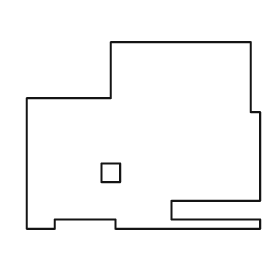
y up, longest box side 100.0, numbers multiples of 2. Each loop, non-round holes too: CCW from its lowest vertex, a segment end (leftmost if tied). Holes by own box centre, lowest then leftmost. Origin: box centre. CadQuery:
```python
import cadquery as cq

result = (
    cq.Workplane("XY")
    .moveTo(-50.0, -40.0)
    .lineTo(-38.0, -40.0)
    .lineTo(-38.0, -36.0)
    .lineTo(-12.0, -36.0)
    .lineTo(-12.0, -40.0)
    .lineTo(50.0, -40.0)
    .lineTo(50.0, -36.0)
    .lineTo(12.0, -36.0)
    .lineTo(12.0, -28.0)
    .lineTo(50.0, -28.0)
    .lineTo(50.0, 10.0)
    .lineTo(46.0, 10.0)
    .lineTo(46.0, 40.0)
    .lineTo(-14.0, 40.0)
    .lineTo(-14.0, 16.0)
    .lineTo(-50.0, 16.0)
    .close()
    .moveTo(-18.0, -20.0)
    .lineTo(-10.0, -20.0)
    .lineTo(-10.0, -12.0)
    .lineTo(-18.0, -12.0)
    .close()
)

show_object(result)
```